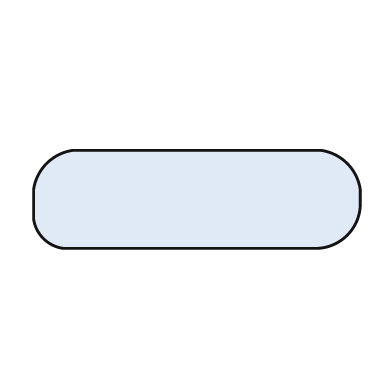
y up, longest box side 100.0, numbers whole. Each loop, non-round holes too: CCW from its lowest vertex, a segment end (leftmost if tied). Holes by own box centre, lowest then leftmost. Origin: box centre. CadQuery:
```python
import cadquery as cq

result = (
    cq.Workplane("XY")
    .moveTo(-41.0, -15.0)
    .lineTo(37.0, -15.0)
    .threePointArc((46.0, -11.0), (50.0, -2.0))
    .lineTo(50.0, 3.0)
    .threePointArc((46.0, 11.0), (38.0, 15.0))
    .lineTo(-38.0, 15.0)
    .threePointArc((-46.0, 11.0), (-50.0, 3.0))
    .lineTo(-50.0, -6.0)
    .threePointArc((-47.0, -12.0), (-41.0, -15.0))
    .close()
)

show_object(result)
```